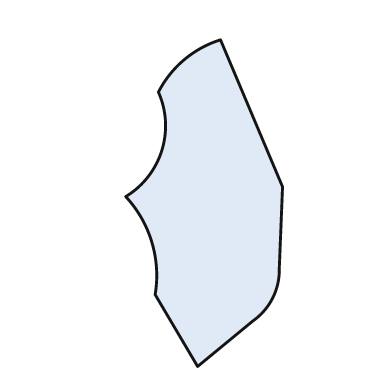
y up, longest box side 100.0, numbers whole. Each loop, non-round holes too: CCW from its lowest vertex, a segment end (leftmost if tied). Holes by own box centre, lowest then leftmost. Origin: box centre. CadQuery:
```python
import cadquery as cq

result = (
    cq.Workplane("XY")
    .moveTo(-2.0, -50.0)
    .lineTo(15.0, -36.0)
    .threePointArc((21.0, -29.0), (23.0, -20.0))
    .lineTo(24.0, 5.0)
    .lineTo(5.0, 50.0)
    .threePointArc((-6.0, 44.0), (-14.0, 34.0))
    .threePointArc((-13.0, 16.0), (-24.0, 2.0))
    .threePointArc((-16.0, -12.0), (-15.0, -28.0))
    .close()
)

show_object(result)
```